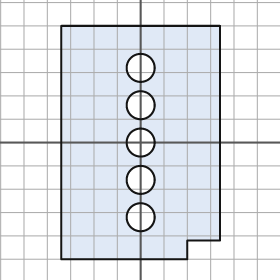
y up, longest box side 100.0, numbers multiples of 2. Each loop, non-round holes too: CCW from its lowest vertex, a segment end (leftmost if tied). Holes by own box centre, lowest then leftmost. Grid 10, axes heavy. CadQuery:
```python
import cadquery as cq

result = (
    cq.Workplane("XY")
    .moveTo(-34.0, -50.0)
    .lineTo(20.0, -50.0)
    .lineTo(20.0, -42.0)
    .lineTo(34.0, -42.0)
    .lineTo(34.0, 50.0)
    .lineTo(-34.0, 50.0)
    .close()
    .moveTo(0.0, -32.0)
    .circle(6.0)
    .moveTo(0.0, -16.0)
    .circle(6.0)
    .moveTo(0.0, 0.0)
    .circle(6.0)
    .moveTo(0.0, 16.0)
    .circle(6.0)
    .moveTo(0.0, 32.0)
    .circle(6.0)
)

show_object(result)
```